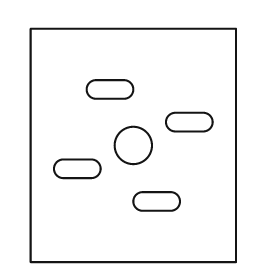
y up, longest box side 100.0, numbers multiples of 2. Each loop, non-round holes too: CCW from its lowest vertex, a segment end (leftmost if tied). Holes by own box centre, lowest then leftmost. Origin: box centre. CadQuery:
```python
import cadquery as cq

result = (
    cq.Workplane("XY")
    .moveTo(-44.0, -50.0)
    .lineTo(44.0, -50.0)
    .lineTo(44.0, 50.0)
    .lineTo(-44.0, 50.0)
    .close()
    .moveTo(4.0, -28.0)
    .lineTo(16.0, -28.0)
    .threePointArc((20.0, -24.0), (16.0, -20.0))
    .lineTo(4.0, -20.0)
    .threePointArc((0.0, -24.0), (4.0, -28.0))
    .close()
    .moveTo(-30.0, -14.0)
    .lineTo(-18.0, -14.0)
    .threePointArc((-14.0, -10.0), (-18.0, -6.0))
    .lineTo(-30.0, -6.0)
    .threePointArc((-34.0, -10.0), (-30.0, -14.0))
    .close()
    .moveTo(0.0, 0.0)
    .circle(8.0)
    .moveTo(18.0, 6.0)
    .lineTo(30.0, 6.0)
    .threePointArc((34.0, 10.0), (30.0, 14.0))
    .lineTo(18.0, 14.0)
    .threePointArc((14.0, 10.0), (18.0, 6.0))
    .close()
    .moveTo(-16.0, 20.0)
    .lineTo(-4.0, 20.0)
    .threePointArc((0.0, 24.0), (-4.0, 28.0))
    .lineTo(-16.0, 28.0)
    .threePointArc((-20.0, 24.0), (-16.0, 20.0))
    .close()
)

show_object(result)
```